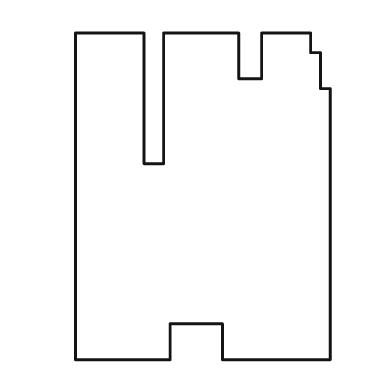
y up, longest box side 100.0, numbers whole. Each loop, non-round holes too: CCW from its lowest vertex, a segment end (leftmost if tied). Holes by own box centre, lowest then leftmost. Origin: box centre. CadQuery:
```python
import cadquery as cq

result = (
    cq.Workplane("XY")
    .moveTo(-39.0, -50.0)
    .lineTo(-10.0, -50.0)
    .lineTo(-10.0, -39.0)
    .lineTo(6.0, -39.0)
    .lineTo(6.0, -50.0)
    .lineTo(39.0, -50.0)
    .lineTo(39.0, 33.0)
    .lineTo(36.0, 33.0)
    .lineTo(36.0, 44.0)
    .lineTo(33.0, 44.0)
    .lineTo(33.0, 50.0)
    .lineTo(18.0, 50.0)
    .lineTo(18.0, 36.0)
    .lineTo(11.0, 36.0)
    .lineTo(11.0, 50.0)
    .lineTo(-12.0, 50.0)
    .lineTo(-12.0, 10.0)
    .lineTo(-18.0, 10.0)
    .lineTo(-18.0, 50.0)
    .lineTo(-39.0, 50.0)
    .close()
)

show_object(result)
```